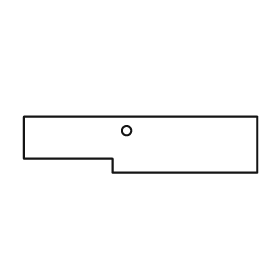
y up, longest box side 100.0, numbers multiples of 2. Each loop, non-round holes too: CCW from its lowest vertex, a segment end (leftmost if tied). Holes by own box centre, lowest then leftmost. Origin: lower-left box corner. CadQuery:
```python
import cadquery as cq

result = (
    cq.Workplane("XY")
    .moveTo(38.0, 0.0)
    .lineTo(100.0, 0.0)
    .lineTo(100.0, 24.0)
    .lineTo(0.0, 24.0)
    .lineTo(0.0, 6.0)
    .lineTo(38.0, 6.0)
    .close()
    .moveTo(44.0, 18.0)
    .circle(2.0)
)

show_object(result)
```